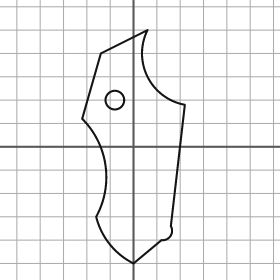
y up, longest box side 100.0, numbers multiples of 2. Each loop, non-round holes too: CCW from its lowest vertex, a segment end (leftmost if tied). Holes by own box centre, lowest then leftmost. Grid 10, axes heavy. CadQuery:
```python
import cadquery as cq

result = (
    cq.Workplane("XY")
    .moveTo(0.0, -50.0)
    .lineTo(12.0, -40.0)
    .threePointArc((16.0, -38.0), (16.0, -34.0))
    .lineTo(22.0, 18.0)
    .threePointArc((6.0, 30.0), (6.0, 50.0))
    .lineTo(-14.0, 40.0)
    .lineTo(-22.0, 12.0)
    .threePointArc((-12.0, -8.0), (-16.0, -30.0))
    .threePointArc((-10.0, -42.0), (0.0, -50.0))
    .close()
    .moveTo(-8.0, 20.0)
    .circle(4.0)
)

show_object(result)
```